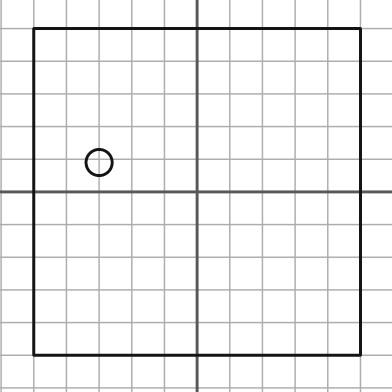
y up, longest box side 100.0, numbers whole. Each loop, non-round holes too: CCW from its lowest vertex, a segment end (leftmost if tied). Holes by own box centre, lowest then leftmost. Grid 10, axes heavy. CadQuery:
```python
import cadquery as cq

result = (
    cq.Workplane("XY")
    .moveTo(-50.0, -50.0)
    .lineTo(50.0, -50.0)
    .lineTo(50.0, 50.0)
    .lineTo(-50.0, 50.0)
    .close()
    .moveTo(-30.0, 9.0)
    .circle(4.0)
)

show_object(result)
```